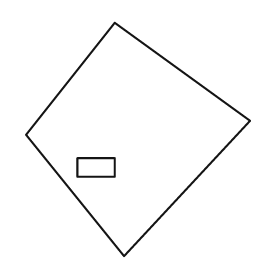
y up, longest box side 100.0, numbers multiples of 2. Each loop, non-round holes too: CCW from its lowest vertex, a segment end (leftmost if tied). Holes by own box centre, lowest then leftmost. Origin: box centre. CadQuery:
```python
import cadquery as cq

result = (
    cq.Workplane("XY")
    .moveTo(-6.0, -50.0)
    .lineTo(48.0, 8.0)
    .lineTo(-10.0, 50.0)
    .lineTo(-48.0, 2.0)
    .close()
    .moveTo(-26.0, -16.0)
    .lineTo(-10.0, -16.0)
    .lineTo(-10.0, -8.0)
    .lineTo(-26.0, -8.0)
    .close()
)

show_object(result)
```